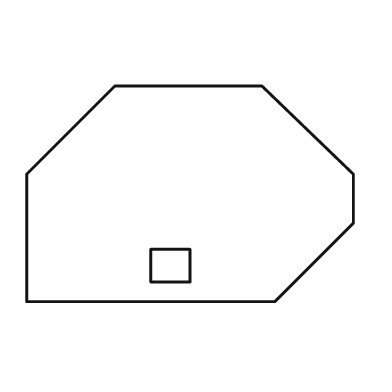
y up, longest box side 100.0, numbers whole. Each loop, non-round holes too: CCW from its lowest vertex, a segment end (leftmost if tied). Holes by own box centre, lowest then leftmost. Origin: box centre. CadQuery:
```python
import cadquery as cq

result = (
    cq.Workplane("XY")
    .moveTo(-50.0, -33.0)
    .lineTo(26.0, -33.0)
    .lineTo(50.0, -9.0)
    .lineTo(50.0, 6.0)
    .lineTo(22.0, 33.0)
    .lineTo(-23.0, 33.0)
    .lineTo(-50.0, 6.0)
    .close()
    .moveTo(-12.0, -27.0)
    .lineTo(0.0, -27.0)
    .lineTo(0.0, -17.0)
    .lineTo(-12.0, -17.0)
    .close()
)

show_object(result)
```